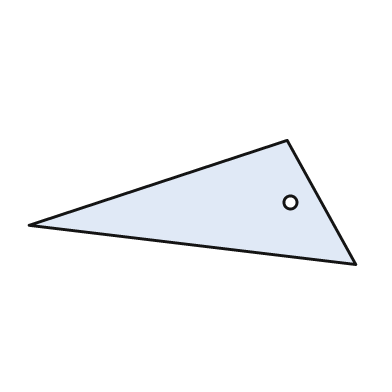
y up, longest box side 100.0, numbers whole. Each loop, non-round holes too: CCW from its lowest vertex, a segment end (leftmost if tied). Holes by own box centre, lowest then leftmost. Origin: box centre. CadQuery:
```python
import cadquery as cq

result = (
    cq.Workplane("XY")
    .moveTo(50.0, -19.0)
    .lineTo(29.0, 19.0)
    .lineTo(-50.0, -7.0)
    .close()
    .moveTo(30.0, 0.0)
    .circle(2.0)
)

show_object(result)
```